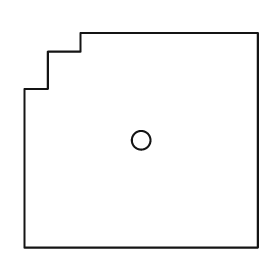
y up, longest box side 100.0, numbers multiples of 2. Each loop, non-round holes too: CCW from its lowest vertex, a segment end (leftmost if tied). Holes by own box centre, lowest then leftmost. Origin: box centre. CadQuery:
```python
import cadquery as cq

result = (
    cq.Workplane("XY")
    .moveTo(-50.0, -46.0)
    .lineTo(50.0, -46.0)
    .lineTo(50.0, 46.0)
    .lineTo(-26.0, 46.0)
    .lineTo(-26.0, 38.0)
    .lineTo(-40.0, 38.0)
    .lineTo(-40.0, 22.0)
    .lineTo(-50.0, 22.0)
    .close()
    .moveTo(0.0, 0.0)
    .circle(4.0)
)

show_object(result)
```